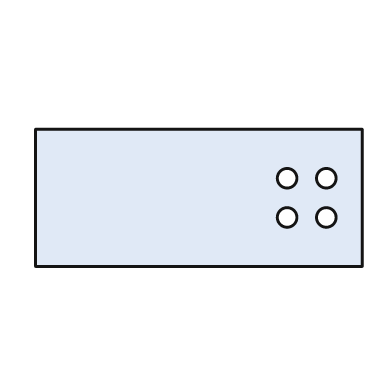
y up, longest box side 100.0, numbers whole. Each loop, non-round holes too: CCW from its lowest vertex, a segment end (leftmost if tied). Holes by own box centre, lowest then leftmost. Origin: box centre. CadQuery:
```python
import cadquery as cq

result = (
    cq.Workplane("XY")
    .moveTo(-50.0, -21.0)
    .lineTo(50.0, -21.0)
    .lineTo(50.0, 21.0)
    .lineTo(-50.0, 21.0)
    .close()
    .moveTo(27.0, -6.0)
    .circle(3.0)
    .moveTo(39.0, -6.0)
    .circle(3.0)
    .moveTo(27.0, 6.0)
    .circle(3.0)
    .moveTo(39.0, 6.0)
    .circle(3.0)
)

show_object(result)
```